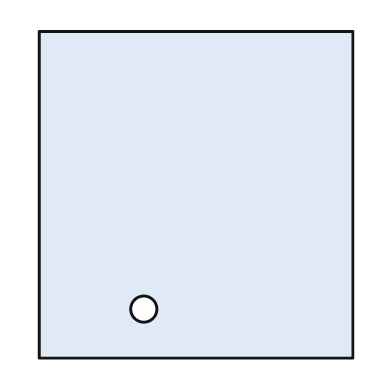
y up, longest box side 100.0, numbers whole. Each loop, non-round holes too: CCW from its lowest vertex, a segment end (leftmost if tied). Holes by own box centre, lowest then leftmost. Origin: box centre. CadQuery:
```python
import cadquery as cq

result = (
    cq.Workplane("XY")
    .moveTo(-48.0, -50.0)
    .lineTo(48.0, -50.0)
    .lineTo(48.0, 50.0)
    .lineTo(-48.0, 50.0)
    .close()
    .moveTo(-16.0, -35.0)
    .circle(4.0)
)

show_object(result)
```